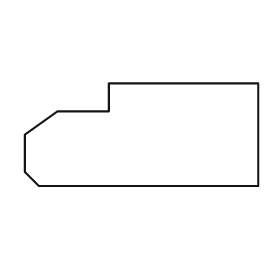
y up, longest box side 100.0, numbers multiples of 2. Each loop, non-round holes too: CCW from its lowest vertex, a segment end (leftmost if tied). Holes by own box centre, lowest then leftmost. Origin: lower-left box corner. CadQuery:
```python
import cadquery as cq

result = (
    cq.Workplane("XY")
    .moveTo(6.0, 0.0)
    .lineTo(100.0, 0.0)
    .lineTo(100.0, 44.0)
    .lineTo(36.0, 44.0)
    .lineTo(36.0, 32.0)
    .lineTo(14.0, 32.0)
    .lineTo(0.0, 22.0)
    .lineTo(0.0, 6.0)
    .close()
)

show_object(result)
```